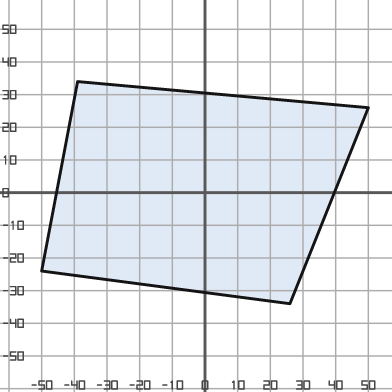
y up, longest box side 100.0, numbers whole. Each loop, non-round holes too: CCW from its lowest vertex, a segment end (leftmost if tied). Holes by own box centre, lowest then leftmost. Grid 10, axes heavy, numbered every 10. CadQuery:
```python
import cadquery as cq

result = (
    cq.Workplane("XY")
    .moveTo(26.0, -34.0)
    .lineTo(50.0, 26.0)
    .lineTo(-39.0, 34.0)
    .lineTo(-50.0, -24.0)
    .close()
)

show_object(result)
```